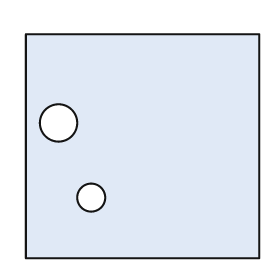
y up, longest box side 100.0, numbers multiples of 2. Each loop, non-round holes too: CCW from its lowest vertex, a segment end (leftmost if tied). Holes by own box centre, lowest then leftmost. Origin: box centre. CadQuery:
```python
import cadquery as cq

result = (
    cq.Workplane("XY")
    .moveTo(-50.0, -48.0)
    .lineTo(50.0, -48.0)
    .lineTo(50.0, 48.0)
    .lineTo(-50.0, 48.0)
    .close()
    .moveTo(-22.0, -22.0)
    .circle(6.0)
    .moveTo(-36.0, 10.0)
    .circle(8.0)
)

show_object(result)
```